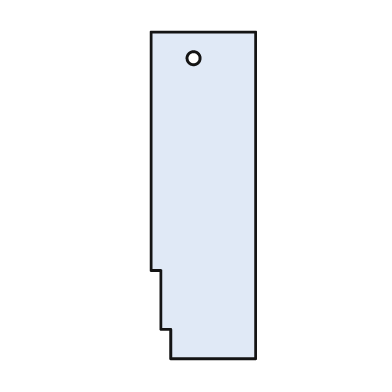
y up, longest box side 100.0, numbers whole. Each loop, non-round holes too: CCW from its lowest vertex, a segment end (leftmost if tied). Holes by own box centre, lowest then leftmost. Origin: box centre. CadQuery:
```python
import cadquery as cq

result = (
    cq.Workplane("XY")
    .moveTo(-10.0, -50.0)
    .lineTo(16.0, -50.0)
    .lineTo(16.0, 50.0)
    .lineTo(-16.0, 50.0)
    .lineTo(-16.0, -23.0)
    .lineTo(-13.0, -23.0)
    .lineTo(-13.0, -41.0)
    .lineTo(-10.0, -41.0)
    .close()
    .moveTo(-3.0, 42.0)
    .circle(2.0)
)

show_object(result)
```